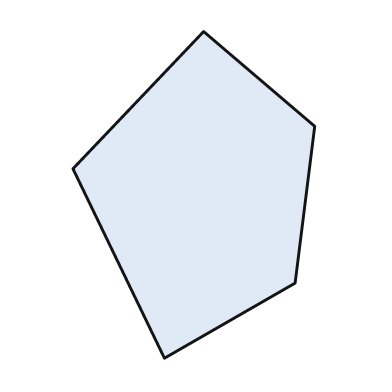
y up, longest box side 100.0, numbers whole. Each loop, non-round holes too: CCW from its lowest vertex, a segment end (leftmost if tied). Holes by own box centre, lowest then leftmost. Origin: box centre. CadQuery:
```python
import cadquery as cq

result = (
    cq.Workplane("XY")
    .moveTo(-9.0, -50.0)
    .lineTo(31.0, -27.0)
    .lineTo(37.0, 21.0)
    .lineTo(3.0, 50.0)
    .lineTo(-37.0, 8.0)
    .close()
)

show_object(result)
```